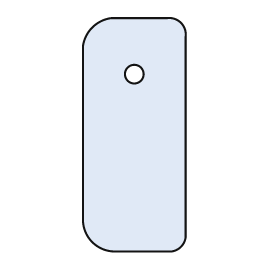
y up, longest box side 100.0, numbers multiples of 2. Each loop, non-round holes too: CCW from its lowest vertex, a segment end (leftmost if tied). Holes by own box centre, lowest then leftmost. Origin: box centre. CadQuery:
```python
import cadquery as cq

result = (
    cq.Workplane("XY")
    .moveTo(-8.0, -50.0)
    .lineTo(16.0, -50.0)
    .threePointArc((20.0, -48.0), (22.0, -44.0))
    .lineTo(22.0, 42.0)
    .threePointArc((20.0, 48.0), (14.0, 50.0))
    .lineTo(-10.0, 50.0)
    .threePointArc((-18.0, 46.0), (-22.0, 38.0))
    .lineTo(-22.0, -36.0)
    .threePointArc((-18.0, -46.0), (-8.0, -50.0))
    .close()
    .moveTo(0.0, 26.0)
    .circle(4.0)
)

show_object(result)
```